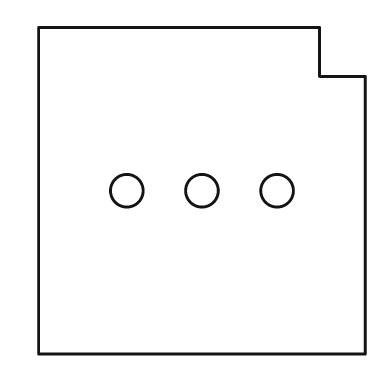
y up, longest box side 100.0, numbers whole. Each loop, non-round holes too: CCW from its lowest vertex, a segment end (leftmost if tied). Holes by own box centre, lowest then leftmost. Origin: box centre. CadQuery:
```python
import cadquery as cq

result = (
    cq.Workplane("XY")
    .moveTo(-50.0, -50.0)
    .lineTo(50.0, -50.0)
    .lineTo(50.0, 35.0)
    .lineTo(36.0, 35.0)
    .lineTo(36.0, 50.0)
    .lineTo(-50.0, 50.0)
    .close()
    .moveTo(-23.0, 0.0)
    .circle(5.0)
    .moveTo(0.0, 0.0)
    .circle(5.0)
    .moveTo(23.0, 0.0)
    .circle(5.0)
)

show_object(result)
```